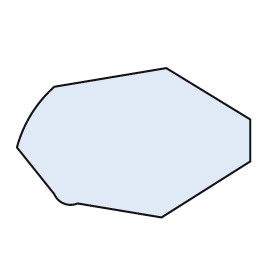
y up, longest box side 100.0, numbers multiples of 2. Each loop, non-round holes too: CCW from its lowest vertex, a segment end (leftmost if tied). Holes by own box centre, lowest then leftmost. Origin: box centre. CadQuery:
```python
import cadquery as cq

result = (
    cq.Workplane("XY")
    .moveTo(12.0, -32.0)
    .lineTo(50.0, -8.0)
    .lineTo(50.0, 10.0)
    .lineTo(14.0, 32.0)
    .lineTo(-34.0, 24.0)
    .threePointArc((-44.0, 12.0), (-50.0, -2.0))
    .lineTo(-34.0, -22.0)
    .threePointArc((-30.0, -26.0), (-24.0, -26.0))
    .close()
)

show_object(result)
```